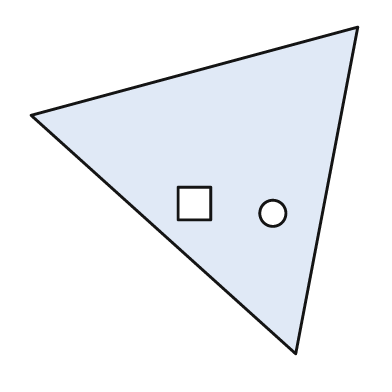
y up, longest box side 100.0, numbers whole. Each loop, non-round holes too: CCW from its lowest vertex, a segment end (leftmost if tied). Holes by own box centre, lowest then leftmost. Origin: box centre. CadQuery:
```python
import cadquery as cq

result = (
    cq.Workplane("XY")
    .moveTo(31.0, -50.0)
    .lineTo(50.0, 50.0)
    .lineTo(-50.0, 23.0)
    .close()
    .moveTo(24.0, -7.0)
    .circle(4.0)
    .moveTo(-5.0, -9.0)
    .lineTo(5.0, -9.0)
    .lineTo(5.0, 1.0)
    .lineTo(-5.0, 1.0)
    .close()
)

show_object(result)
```